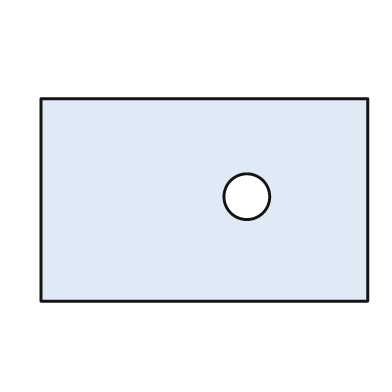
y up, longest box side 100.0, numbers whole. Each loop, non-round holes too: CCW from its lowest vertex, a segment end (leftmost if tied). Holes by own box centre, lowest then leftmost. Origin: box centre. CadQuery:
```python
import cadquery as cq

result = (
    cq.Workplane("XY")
    .moveTo(-50.0, -31.0)
    .lineTo(50.0, -31.0)
    .lineTo(50.0, 31.0)
    .lineTo(-50.0, 31.0)
    .close()
    .moveTo(13.0, 1.0)
    .circle(7.0)
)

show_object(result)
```